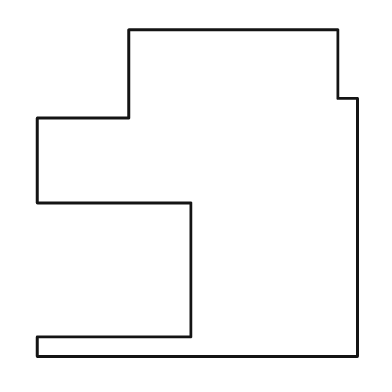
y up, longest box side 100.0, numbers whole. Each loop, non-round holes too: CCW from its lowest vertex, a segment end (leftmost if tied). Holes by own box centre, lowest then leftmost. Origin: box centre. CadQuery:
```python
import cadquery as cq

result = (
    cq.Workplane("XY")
    .moveTo(-49.0, -50.0)
    .lineTo(49.0, -50.0)
    .lineTo(49.0, 29.0)
    .lineTo(43.0, 29.0)
    .lineTo(43.0, 50.0)
    .lineTo(-21.0, 50.0)
    .lineTo(-21.0, 23.0)
    .lineTo(-49.0, 23.0)
    .lineTo(-49.0, -3.0)
    .lineTo(-2.0, -3.0)
    .lineTo(-2.0, -44.0)
    .lineTo(-49.0, -44.0)
    .close()
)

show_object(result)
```